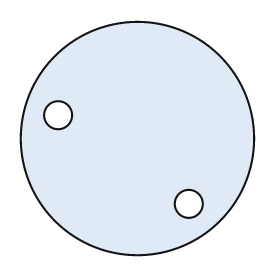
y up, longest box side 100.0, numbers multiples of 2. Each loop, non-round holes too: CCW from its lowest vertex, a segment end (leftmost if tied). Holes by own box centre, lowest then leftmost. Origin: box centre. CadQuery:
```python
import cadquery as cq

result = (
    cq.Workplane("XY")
    .moveTo(0.0, 0.0)
    .circle(50.0)
    .moveTo(22.0, -28.0)
    .circle(6.0)
    .moveTo(-34.0, 10.0)
    .circle(6.0)
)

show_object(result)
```